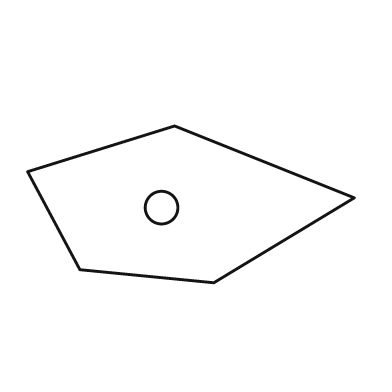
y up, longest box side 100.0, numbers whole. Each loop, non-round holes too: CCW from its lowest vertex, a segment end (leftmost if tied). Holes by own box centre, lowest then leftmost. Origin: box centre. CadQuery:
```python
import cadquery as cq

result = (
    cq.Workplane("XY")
    .moveTo(7.0, -24.0)
    .lineTo(50.0, 2.0)
    .lineTo(-5.0, 24.0)
    .lineTo(-50.0, 10.0)
    .lineTo(-34.0, -20.0)
    .close()
    .moveTo(-9.0, -1.0)
    .circle(5.0)
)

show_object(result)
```